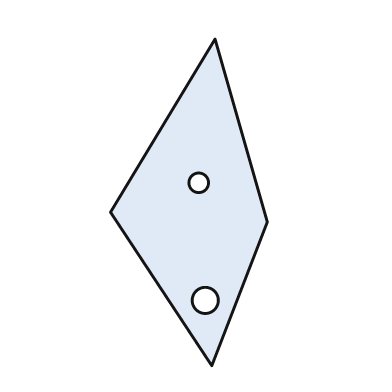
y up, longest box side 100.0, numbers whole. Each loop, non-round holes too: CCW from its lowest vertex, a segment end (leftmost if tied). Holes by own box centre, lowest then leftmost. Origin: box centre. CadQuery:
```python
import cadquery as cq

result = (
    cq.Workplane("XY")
    .moveTo(7.0, -50.0)
    .lineTo(24.0, -6.0)
    .lineTo(8.0, 50.0)
    .lineTo(-24.0, -3.0)
    .close()
    .moveTo(5.0, -30.0)
    .circle(4.0)
    .moveTo(3.0, 6.0)
    .circle(3.0)
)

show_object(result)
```